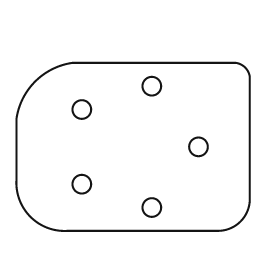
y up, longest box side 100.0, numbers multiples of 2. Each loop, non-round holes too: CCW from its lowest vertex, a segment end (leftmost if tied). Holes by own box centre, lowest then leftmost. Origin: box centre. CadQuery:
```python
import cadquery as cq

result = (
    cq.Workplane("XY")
    .moveTo(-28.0, -36.0)
    .lineTo(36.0, -36.0)
    .threePointArc((46.0, -32.0), (50.0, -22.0))
    .lineTo(50.0, 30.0)
    .threePointArc((48.0, 34.0), (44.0, 36.0))
    .lineTo(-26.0, 36.0)
    .threePointArc((-42.0, 28.0), (-50.0, 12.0))
    .lineTo(-50.0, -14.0)
    .threePointArc((-44.0, -30.0), (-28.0, -36.0))
    .close()
    .moveTo(8.0, -26.0)
    .circle(4.0)
    .moveTo(-22.0, -16.0)
    .circle(4.0)
    .moveTo(28.0, 0.0)
    .circle(4.0)
    .moveTo(-22.0, 16.0)
    .circle(4.0)
    .moveTo(8.0, 26.0)
    .circle(4.0)
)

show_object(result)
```